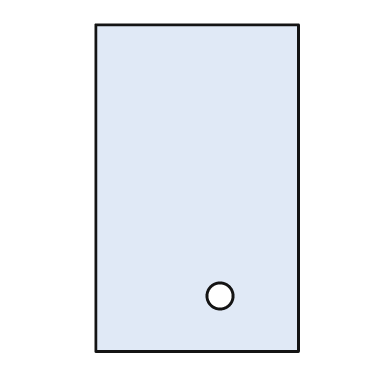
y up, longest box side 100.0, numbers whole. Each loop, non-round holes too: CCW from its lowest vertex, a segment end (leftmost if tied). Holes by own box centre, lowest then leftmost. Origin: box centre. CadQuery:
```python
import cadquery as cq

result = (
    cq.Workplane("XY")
    .moveTo(-31.0, -50.0)
    .lineTo(31.0, -50.0)
    .lineTo(31.0, 50.0)
    .lineTo(-31.0, 50.0)
    .close()
    .moveTo(7.0, -33.0)
    .circle(4.0)
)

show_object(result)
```